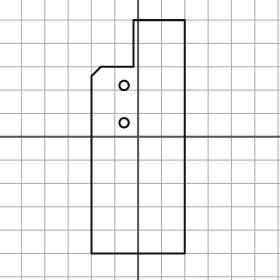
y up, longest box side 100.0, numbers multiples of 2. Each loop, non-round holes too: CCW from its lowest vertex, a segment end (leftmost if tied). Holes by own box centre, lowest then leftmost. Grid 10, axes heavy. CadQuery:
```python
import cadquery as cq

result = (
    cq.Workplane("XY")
    .moveTo(-20.0, -50.0)
    .lineTo(20.0, -50.0)
    .lineTo(20.0, 50.0)
    .lineTo(-2.0, 50.0)
    .lineTo(-2.0, 30.0)
    .lineTo(-16.0, 30.0)
    .lineTo(-20.0, 26.0)
    .close()
    .moveTo(-6.0, 6.0)
    .circle(2.0)
    .moveTo(-6.0, 22.0)
    .circle(2.0)
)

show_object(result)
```